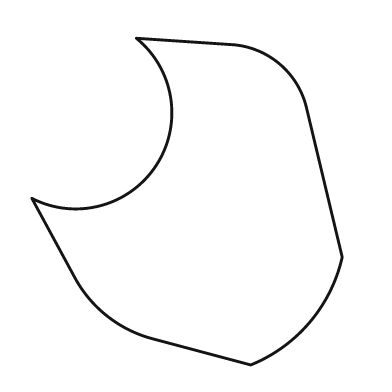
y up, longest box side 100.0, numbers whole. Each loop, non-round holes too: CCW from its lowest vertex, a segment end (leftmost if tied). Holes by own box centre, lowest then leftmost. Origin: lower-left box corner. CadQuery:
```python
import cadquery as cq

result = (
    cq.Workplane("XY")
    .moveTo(67.0, 0.0)
    .threePointArc((85.0, 13.0), (95.0, 33.0))
    .lineTo(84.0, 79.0)
    .threePointArc((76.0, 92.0), (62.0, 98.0))
    .lineTo(32.0, 100.0)
    .threePointArc((38.0, 61.0), (0.0, 51.0))
    .lineTo(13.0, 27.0)
    .threePointArc((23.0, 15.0), (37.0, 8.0))
    .close()
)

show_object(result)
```